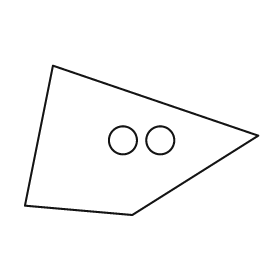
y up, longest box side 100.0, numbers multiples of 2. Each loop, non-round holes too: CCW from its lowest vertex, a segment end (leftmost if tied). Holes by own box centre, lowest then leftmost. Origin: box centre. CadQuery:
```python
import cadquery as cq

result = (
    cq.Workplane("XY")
    .moveTo(-4.0, -32.0)
    .lineTo(50.0, 2.0)
    .lineTo(-38.0, 32.0)
    .lineTo(-50.0, -28.0)
    .close()
    .moveTo(-8.0, 0.0)
    .circle(6.0)
    .moveTo(8.0, 0.0)
    .circle(6.0)
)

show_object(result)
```